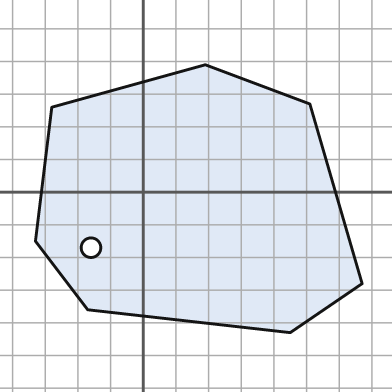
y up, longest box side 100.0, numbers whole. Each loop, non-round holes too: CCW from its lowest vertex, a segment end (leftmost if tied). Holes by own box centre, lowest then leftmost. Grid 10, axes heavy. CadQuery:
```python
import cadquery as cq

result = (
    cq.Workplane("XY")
    .moveTo(45.0, -43.0)
    .lineTo(67.0, -28.0)
    .lineTo(51.0, 27.0)
    .lineTo(19.0, 39.0)
    .lineTo(-28.0, 26.0)
    .lineTo(-33.0, -15.0)
    .lineTo(-17.0, -36.0)
    .close()
    .moveTo(-16.0, -17.0)
    .circle(3.0)
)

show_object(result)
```